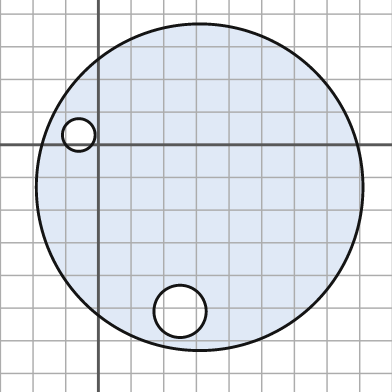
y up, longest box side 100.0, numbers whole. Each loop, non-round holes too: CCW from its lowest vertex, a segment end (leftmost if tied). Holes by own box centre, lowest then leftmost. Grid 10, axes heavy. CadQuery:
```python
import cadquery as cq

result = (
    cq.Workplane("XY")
    .moveTo(31.0, -13.0)
    .circle(50.0)
    .moveTo(25.0, -51.0)
    .circle(8.0)
    .moveTo(-6.0, 3.0)
    .circle(5.0)
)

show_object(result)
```